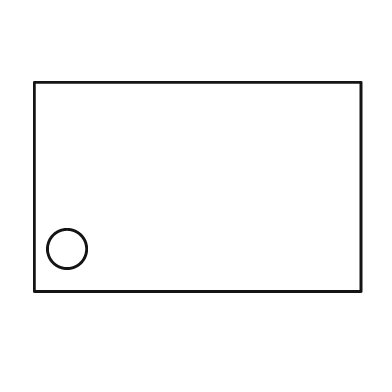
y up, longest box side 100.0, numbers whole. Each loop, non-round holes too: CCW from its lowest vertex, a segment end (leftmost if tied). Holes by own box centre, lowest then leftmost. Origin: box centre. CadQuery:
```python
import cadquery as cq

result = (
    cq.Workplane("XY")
    .moveTo(-50.0, -32.0)
    .lineTo(50.0, -32.0)
    .lineTo(50.0, 32.0)
    .lineTo(-50.0, 32.0)
    .close()
    .moveTo(-40.0, -19.0)
    .circle(6.0)
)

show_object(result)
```